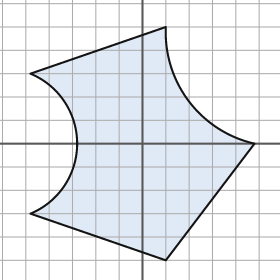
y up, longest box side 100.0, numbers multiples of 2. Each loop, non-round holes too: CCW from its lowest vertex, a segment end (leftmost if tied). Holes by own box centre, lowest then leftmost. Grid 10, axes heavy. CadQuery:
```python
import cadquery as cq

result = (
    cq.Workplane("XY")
    .moveTo(10.0, -50.0)
    .lineTo(48.0, 0.0)
    .threePointArc((20.0, 18.0), (10.0, 50.0))
    .lineTo(-48.0, 30.0)
    .threePointArc((-28.0, 0.0), (-48.0, -30.0))
    .close()
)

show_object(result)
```